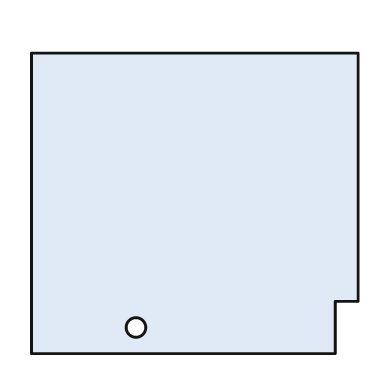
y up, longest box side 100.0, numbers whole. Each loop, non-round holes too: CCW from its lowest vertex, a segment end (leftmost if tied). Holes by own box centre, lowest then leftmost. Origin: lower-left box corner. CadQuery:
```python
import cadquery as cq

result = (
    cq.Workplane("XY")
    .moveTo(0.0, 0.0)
    .lineTo(93.0, 0.0)
    .lineTo(93.0, 16.0)
    .lineTo(100.0, 16.0)
    .lineTo(100.0, 92.0)
    .lineTo(0.0, 92.0)
    .close()
    .moveTo(32.0, 8.0)
    .circle(3.0)
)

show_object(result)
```